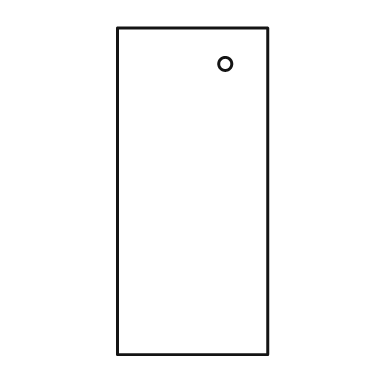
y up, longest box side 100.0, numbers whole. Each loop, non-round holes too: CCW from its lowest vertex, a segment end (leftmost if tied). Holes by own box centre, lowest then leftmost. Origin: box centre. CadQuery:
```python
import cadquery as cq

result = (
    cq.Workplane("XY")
    .moveTo(-23.0, -50.0)
    .lineTo(23.0, -50.0)
    .lineTo(23.0, 50.0)
    .lineTo(-23.0, 50.0)
    .close()
    .moveTo(10.0, 39.0)
    .circle(2.0)
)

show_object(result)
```